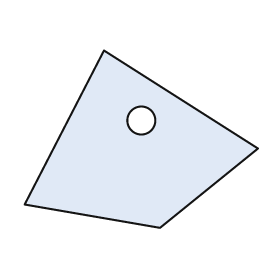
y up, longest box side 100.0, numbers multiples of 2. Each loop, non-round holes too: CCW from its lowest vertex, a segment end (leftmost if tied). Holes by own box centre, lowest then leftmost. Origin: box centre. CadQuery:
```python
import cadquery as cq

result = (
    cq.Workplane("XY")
    .moveTo(8.0, -38.0)
    .lineTo(50.0, -4.0)
    .lineTo(-16.0, 38.0)
    .lineTo(-50.0, -28.0)
    .close()
    .moveTo(0.0, 8.0)
    .circle(6.0)
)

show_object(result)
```